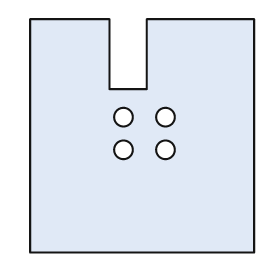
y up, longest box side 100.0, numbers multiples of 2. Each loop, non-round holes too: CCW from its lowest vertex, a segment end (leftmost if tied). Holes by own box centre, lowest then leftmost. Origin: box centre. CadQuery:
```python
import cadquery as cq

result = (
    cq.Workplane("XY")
    .moveTo(-48.0, -50.0)
    .lineTo(48.0, -50.0)
    .lineTo(48.0, 50.0)
    .lineTo(2.0, 50.0)
    .lineTo(2.0, 20.0)
    .lineTo(-14.0, 20.0)
    .lineTo(-14.0, 50.0)
    .lineTo(-48.0, 50.0)
    .close()
    .moveTo(-8.0, -6.0)
    .circle(4.0)
    .moveTo(10.0, -6.0)
    .circle(4.0)
    .moveTo(-8.0, 8.0)
    .circle(4.0)
    .moveTo(10.0, 8.0)
    .circle(4.0)
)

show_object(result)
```